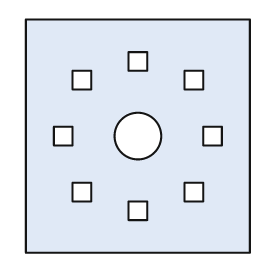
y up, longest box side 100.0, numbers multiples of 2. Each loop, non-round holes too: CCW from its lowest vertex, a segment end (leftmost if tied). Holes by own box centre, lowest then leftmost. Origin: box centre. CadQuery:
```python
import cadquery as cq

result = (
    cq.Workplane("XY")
    .moveTo(-48.0, -50.0)
    .lineTo(48.0, -50.0)
    .lineTo(48.0, 50.0)
    .lineTo(-48.0, 50.0)
    .close()
    .moveTo(-4.0, -36.0)
    .lineTo(4.0, -36.0)
    .lineTo(4.0, -28.0)
    .lineTo(-4.0, -28.0)
    .close()
    .moveTo(-28.0, -28.0)
    .lineTo(-20.0, -28.0)
    .lineTo(-20.0, -20.0)
    .lineTo(-28.0, -20.0)
    .close()
    .moveTo(20.0, -28.0)
    .lineTo(28.0, -28.0)
    .lineTo(28.0, -20.0)
    .lineTo(20.0, -20.0)
    .close()
    .moveTo(-36.0, -4.0)
    .lineTo(-28.0, -4.0)
    .lineTo(-28.0, 4.0)
    .lineTo(-36.0, 4.0)
    .close()
    .moveTo(0.0, 0.0)
    .circle(10.0)
    .moveTo(28.0, -4.0)
    .lineTo(36.0, -4.0)
    .lineTo(36.0, 4.0)
    .lineTo(28.0, 4.0)
    .close()
    .moveTo(-28.0, 20.0)
    .lineTo(-20.0, 20.0)
    .lineTo(-20.0, 28.0)
    .lineTo(-28.0, 28.0)
    .close()
    .moveTo(20.0, 20.0)
    .lineTo(28.0, 20.0)
    .lineTo(28.0, 28.0)
    .lineTo(20.0, 28.0)
    .close()
    .moveTo(-4.0, 28.0)
    .lineTo(4.0, 28.0)
    .lineTo(4.0, 36.0)
    .lineTo(-4.0, 36.0)
    .close()
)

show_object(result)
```